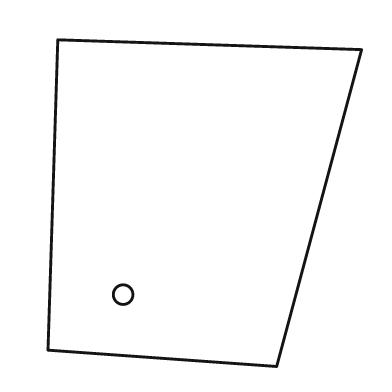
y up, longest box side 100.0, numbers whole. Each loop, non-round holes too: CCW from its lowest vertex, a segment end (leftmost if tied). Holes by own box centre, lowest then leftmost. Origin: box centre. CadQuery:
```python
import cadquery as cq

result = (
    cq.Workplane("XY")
    .moveTo(22.0, -50.0)
    .lineTo(48.0, 47.0)
    .lineTo(-45.0, 50.0)
    .lineTo(-48.0, -45.0)
    .close()
    .moveTo(-25.0, -28.0)
    .circle(3.0)
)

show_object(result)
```